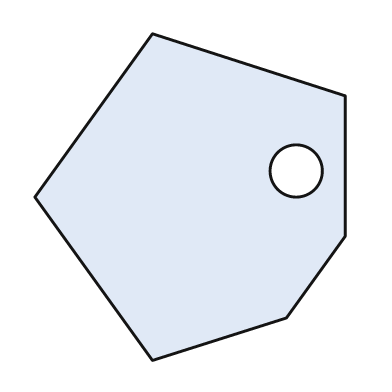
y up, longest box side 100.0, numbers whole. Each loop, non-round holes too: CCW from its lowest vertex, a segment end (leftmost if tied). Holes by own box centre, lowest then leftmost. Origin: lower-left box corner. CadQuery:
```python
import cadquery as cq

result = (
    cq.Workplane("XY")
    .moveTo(36.0, 0.0)
    .lineTo(77.0, 13.0)
    .lineTo(95.0, 38.0)
    .lineTo(95.0, 81.0)
    .lineTo(36.0, 100.0)
    .lineTo(0.0, 50.0)
    .close()
    .moveTo(80.0, 58.0)
    .circle(8.0)
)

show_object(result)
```